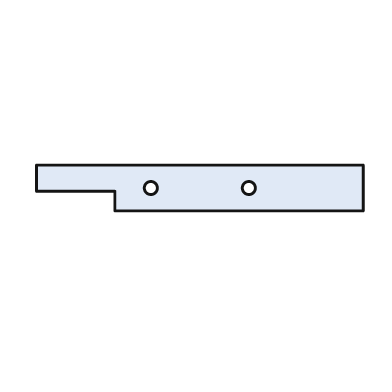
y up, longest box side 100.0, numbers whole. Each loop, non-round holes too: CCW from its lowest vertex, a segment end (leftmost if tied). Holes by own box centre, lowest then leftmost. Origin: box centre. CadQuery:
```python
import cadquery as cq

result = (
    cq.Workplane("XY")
    .moveTo(-26.0, -7.0)
    .lineTo(50.0, -7.0)
    .lineTo(50.0, 7.0)
    .lineTo(-50.0, 7.0)
    .lineTo(-50.0, -1.0)
    .lineTo(-26.0, -1.0)
    .close()
    .moveTo(-15.0, 0.0)
    .circle(2.0)
    .moveTo(15.0, 0.0)
    .circle(2.0)
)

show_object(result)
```